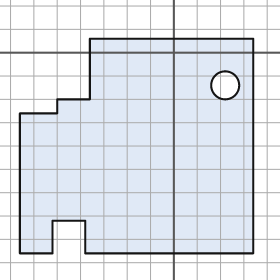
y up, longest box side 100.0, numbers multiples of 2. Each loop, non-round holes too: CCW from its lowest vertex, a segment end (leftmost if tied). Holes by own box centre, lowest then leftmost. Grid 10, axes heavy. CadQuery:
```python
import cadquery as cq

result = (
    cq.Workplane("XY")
    .moveTo(-66.0, -86.0)
    .lineTo(-52.0, -86.0)
    .lineTo(-52.0, -72.0)
    .lineTo(-38.0, -72.0)
    .lineTo(-38.0, -86.0)
    .lineTo(34.0, -86.0)
    .lineTo(34.0, 6.0)
    .lineTo(-36.0, 6.0)
    .lineTo(-36.0, -20.0)
    .lineTo(-50.0, -20.0)
    .lineTo(-50.0, -26.0)
    .lineTo(-66.0, -26.0)
    .close()
    .moveTo(22.0, -14.0)
    .circle(6.0)
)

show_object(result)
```